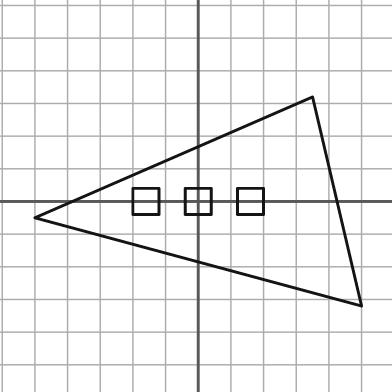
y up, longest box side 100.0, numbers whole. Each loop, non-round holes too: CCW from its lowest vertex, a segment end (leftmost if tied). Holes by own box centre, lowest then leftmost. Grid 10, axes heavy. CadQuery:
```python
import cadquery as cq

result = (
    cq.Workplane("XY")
    .moveTo(50.0, -32.0)
    .lineTo(35.0, 32.0)
    .lineTo(-50.0, -5.0)
    .close()
    .moveTo(-20.0, -4.0)
    .lineTo(-12.0, -4.0)
    .lineTo(-12.0, 4.0)
    .lineTo(-20.0, 4.0)
    .close()
    .moveTo(-4.0, -4.0)
    .lineTo(4.0, -4.0)
    .lineTo(4.0, 4.0)
    .lineTo(-4.0, 4.0)
    .close()
    .moveTo(12.0, -4.0)
    .lineTo(20.0, -4.0)
    .lineTo(20.0, 4.0)
    .lineTo(12.0, 4.0)
    .close()
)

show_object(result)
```